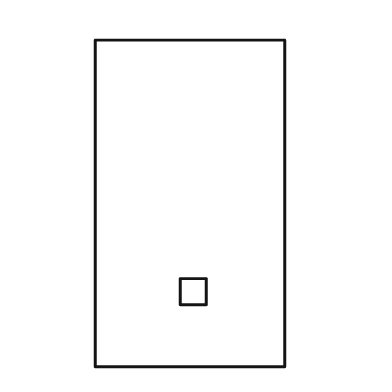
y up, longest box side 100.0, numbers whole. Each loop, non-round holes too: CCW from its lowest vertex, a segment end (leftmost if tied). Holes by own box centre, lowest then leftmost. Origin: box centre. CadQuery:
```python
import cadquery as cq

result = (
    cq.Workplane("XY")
    .moveTo(-29.0, -50.0)
    .lineTo(29.0, -50.0)
    .lineTo(29.0, 50.0)
    .lineTo(-29.0, 50.0)
    .close()
    .moveTo(-3.0, -31.0)
    .lineTo(5.0, -31.0)
    .lineTo(5.0, -23.0)
    .lineTo(-3.0, -23.0)
    .close()
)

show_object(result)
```